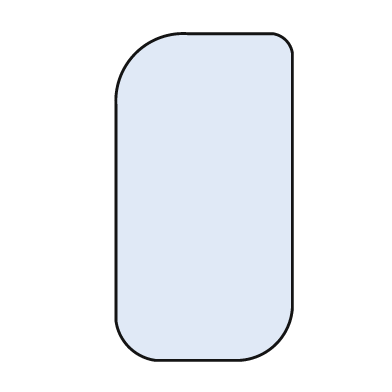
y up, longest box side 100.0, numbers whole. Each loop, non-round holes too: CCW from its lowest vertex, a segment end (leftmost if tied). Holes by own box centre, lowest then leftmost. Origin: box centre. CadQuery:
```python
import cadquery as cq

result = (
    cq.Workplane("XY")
    .moveTo(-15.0, -50.0)
    .lineTo(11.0, -50.0)
    .threePointArc((22.0, -45.0), (27.0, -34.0))
    .lineTo(27.0, 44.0)
    .threePointArc((25.0, 48.0), (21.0, 50.0))
    .lineTo(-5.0, 50.0)
    .threePointArc((-21.0, 44.0), (-27.0, 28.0))
    .lineTo(-27.0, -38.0)
    .threePointArc((-23.0, -46.0), (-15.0, -50.0))
    .close()
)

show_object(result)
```